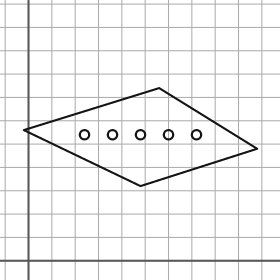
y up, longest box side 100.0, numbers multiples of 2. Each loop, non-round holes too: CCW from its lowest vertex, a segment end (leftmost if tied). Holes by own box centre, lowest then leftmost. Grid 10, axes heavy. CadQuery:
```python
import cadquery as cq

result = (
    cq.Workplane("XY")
    .moveTo(48.0, 32.0)
    .lineTo(98.0, 48.0)
    .lineTo(56.0, 74.0)
    .lineTo(-2.0, 56.0)
    .close()
    .moveTo(24.0, 54.0)
    .circle(2.0)
    .moveTo(36.0, 54.0)
    .circle(2.0)
    .moveTo(48.0, 54.0)
    .circle(2.0)
    .moveTo(60.0, 54.0)
    .circle(2.0)
    .moveTo(72.0, 54.0)
    .circle(2.0)
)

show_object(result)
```